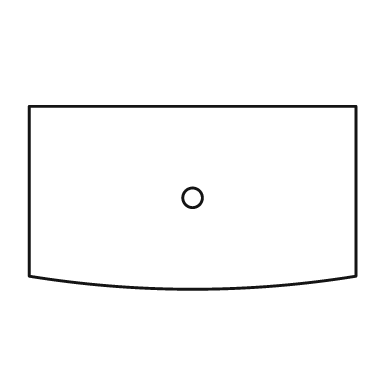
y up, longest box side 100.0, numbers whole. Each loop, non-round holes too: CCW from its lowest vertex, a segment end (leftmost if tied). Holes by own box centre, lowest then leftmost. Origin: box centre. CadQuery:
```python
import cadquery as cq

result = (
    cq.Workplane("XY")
    .moveTo(-50.0, -24.0)
    .threePointArc((0.0, -28.0), (50.0, -24.0))
    .lineTo(50.0, 28.0)
    .lineTo(-50.0, 28.0)
    .close()
    .moveTo(0.0, 0.0)
    .circle(3.0)
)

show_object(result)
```